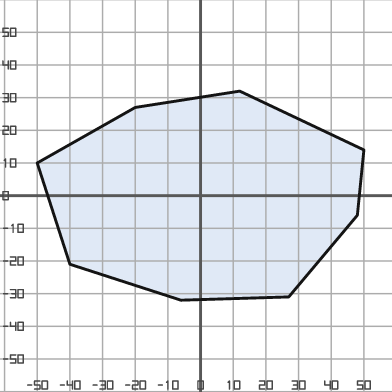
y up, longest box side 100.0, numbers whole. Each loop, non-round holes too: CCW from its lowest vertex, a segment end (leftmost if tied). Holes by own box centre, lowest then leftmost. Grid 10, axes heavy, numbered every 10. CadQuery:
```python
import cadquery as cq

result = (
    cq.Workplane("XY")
    .moveTo(-6.0, -32.0)
    .lineTo(27.0, -31.0)
    .lineTo(48.0, -6.0)
    .lineTo(50.0, 14.0)
    .lineTo(12.0, 32.0)
    .lineTo(-20.0, 27.0)
    .lineTo(-50.0, 10.0)
    .lineTo(-40.0, -21.0)
    .close()
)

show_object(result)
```